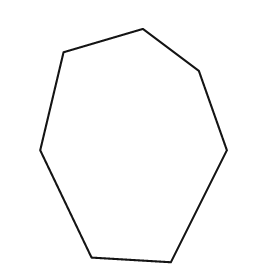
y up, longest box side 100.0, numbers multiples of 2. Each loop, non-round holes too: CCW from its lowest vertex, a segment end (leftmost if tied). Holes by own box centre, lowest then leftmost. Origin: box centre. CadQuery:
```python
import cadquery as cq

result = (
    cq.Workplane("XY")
    .moveTo(16.0, -50.0)
    .lineTo(40.0, -2.0)
    .lineTo(28.0, 32.0)
    .lineTo(4.0, 50.0)
    .lineTo(-30.0, 40.0)
    .lineTo(-40.0, -2.0)
    .lineTo(-18.0, -48.0)
    .close()
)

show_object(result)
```